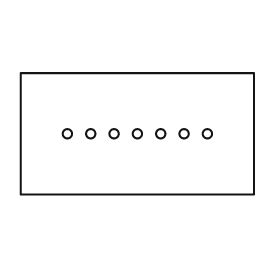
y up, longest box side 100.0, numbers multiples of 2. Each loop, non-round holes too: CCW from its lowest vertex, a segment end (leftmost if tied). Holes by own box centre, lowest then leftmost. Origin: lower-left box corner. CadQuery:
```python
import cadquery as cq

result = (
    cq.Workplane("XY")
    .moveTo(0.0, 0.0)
    .lineTo(100.0, 0.0)
    .lineTo(100.0, 52.0)
    .lineTo(0.0, 52.0)
    .close()
    .moveTo(20.0, 26.0)
    .circle(2.0)
    .moveTo(30.0, 26.0)
    .circle(2.0)
    .moveTo(40.0, 26.0)
    .circle(2.0)
    .moveTo(50.0, 26.0)
    .circle(2.0)
    .moveTo(60.0, 26.0)
    .circle(2.0)
    .moveTo(70.0, 26.0)
    .circle(2.0)
    .moveTo(80.0, 26.0)
    .circle(2.0)
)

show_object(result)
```